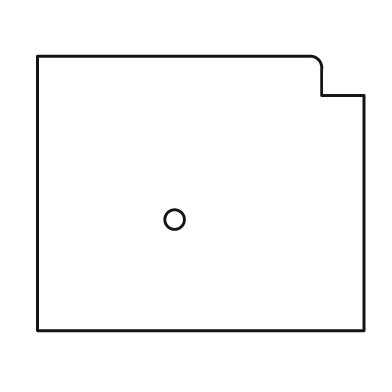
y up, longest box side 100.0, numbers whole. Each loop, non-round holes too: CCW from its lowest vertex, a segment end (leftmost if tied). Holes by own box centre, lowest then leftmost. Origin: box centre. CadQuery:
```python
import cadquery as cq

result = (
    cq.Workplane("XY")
    .moveTo(-50.0, -42.0)
    .lineTo(50.0, -42.0)
    .lineTo(50.0, 30.0)
    .lineTo(37.0, 30.0)
    .lineTo(37.0, 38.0)
    .threePointArc((36.0, 41.0), (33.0, 42.0))
    .lineTo(-50.0, 42.0)
    .close()
    .moveTo(-8.0, -8.0)
    .circle(3.0)
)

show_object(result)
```